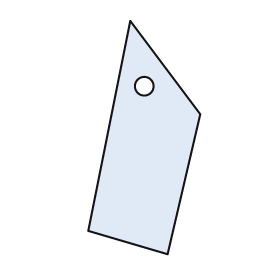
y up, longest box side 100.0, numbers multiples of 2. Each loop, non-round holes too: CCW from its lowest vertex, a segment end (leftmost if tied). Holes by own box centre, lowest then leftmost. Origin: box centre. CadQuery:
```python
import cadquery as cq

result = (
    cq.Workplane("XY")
    .moveTo(10.0, -50.0)
    .lineTo(24.0, 10.0)
    .lineTo(-6.0, 50.0)
    .lineTo(-24.0, -40.0)
    .close()
    .moveTo(0.0, 22.0)
    .circle(4.0)
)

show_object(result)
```